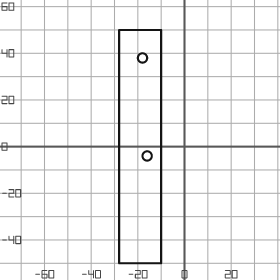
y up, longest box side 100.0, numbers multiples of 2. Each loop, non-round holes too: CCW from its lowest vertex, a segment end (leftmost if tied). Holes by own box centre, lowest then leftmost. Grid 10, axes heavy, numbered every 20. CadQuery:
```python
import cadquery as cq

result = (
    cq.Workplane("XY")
    .moveTo(-28.0, -50.0)
    .lineTo(-10.0, -50.0)
    .lineTo(-10.0, 50.0)
    .lineTo(-28.0, 50.0)
    .close()
    .moveTo(-16.0, -4.0)
    .circle(2.0)
    .moveTo(-18.0, 38.0)
    .circle(2.0)
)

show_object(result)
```